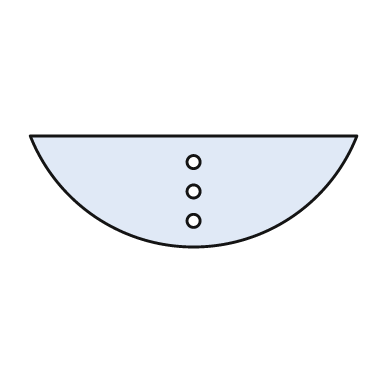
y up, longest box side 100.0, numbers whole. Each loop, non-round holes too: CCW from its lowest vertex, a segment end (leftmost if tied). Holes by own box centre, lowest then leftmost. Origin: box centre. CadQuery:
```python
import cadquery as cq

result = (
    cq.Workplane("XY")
    .moveTo(-50.0, 17.0)
    .threePointArc((0.0, -17.0), (50.0, 17.0))
    .close()
    .moveTo(0.0, -9.0)
    .circle(2.0)
    .moveTo(0.0, 0.0)
    .circle(2.0)
    .moveTo(0.0, 9.0)
    .circle(2.0)
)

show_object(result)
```